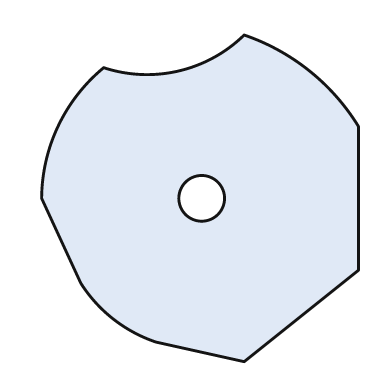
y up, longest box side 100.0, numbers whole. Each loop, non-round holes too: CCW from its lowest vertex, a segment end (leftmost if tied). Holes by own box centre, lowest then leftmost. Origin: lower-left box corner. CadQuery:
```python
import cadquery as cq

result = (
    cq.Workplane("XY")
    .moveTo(62.0, 0.0)
    .lineTo(97.0, 28.0)
    .lineTo(97.0, 72.0)
    .threePointArc((82.0, 89.0), (62.0, 100.0))
    .threePointArc((42.0, 89.0), (19.0, 90.0))
    .threePointArc((5.0, 72.0), (0.0, 50.0))
    .lineTo(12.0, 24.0)
    .threePointArc((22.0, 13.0), (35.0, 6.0))
    .close()
    .moveTo(49.0, 50.0)
    .circle(7.0)
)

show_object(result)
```